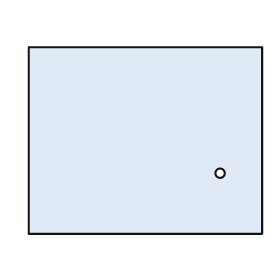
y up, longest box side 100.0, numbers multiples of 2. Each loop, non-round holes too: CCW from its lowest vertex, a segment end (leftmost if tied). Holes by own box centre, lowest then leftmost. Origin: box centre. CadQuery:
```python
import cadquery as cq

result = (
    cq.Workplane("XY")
    .moveTo(-50.0, -40.0)
    .lineTo(50.0, -40.0)
    .lineTo(50.0, 40.0)
    .lineTo(-50.0, 40.0)
    .close()
    .moveTo(32.0, -14.0)
    .circle(2.0)
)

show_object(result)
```